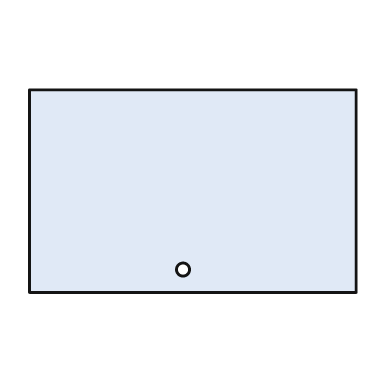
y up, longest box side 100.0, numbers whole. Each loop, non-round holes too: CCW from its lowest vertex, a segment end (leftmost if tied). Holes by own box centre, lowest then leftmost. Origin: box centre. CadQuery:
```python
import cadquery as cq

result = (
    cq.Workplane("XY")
    .moveTo(-50.0, -31.0)
    .lineTo(50.0, -31.0)
    .lineTo(50.0, 31.0)
    .lineTo(-50.0, 31.0)
    .close()
    .moveTo(-3.0, -24.0)
    .circle(2.0)
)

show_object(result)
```